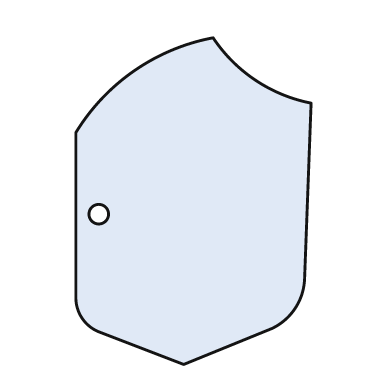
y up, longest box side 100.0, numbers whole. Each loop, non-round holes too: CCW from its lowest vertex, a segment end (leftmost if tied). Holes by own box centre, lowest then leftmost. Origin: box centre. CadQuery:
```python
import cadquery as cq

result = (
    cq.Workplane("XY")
    .moveTo(-3.0, -50.0)
    .lineTo(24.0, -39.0)
    .threePointArc((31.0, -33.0), (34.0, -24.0))
    .lineTo(36.0, 30.0)
    .threePointArc((19.0, 37.0), (6.0, 50.0))
    .threePointArc((-18.0, 40.0), (-36.0, 21.0))
    .lineTo(-36.0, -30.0)
    .threePointArc((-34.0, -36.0), (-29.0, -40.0))
    .close()
    .moveTo(-29.0, -4.0)
    .circle(3.0)
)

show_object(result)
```